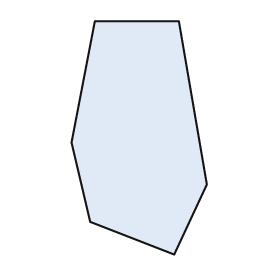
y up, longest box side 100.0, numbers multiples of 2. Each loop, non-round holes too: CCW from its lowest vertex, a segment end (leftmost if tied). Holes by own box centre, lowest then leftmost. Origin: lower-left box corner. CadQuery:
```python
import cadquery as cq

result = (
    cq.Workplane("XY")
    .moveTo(44.0, 0.0)
    .lineTo(58.0, 30.0)
    .lineTo(46.0, 100.0)
    .lineTo(10.0, 100.0)
    .lineTo(0.0, 48.0)
    .lineTo(8.0, 14.0)
    .close()
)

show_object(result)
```